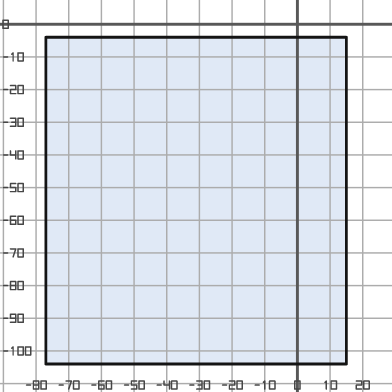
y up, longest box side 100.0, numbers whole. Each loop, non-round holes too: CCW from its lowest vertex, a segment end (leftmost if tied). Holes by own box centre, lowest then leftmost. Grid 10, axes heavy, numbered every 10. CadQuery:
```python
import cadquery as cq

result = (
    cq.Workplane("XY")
    .moveTo(-77.0, -104.0)
    .lineTo(15.0, -104.0)
    .lineTo(15.0, -4.0)
    .lineTo(-77.0, -4.0)
    .close()
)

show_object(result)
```